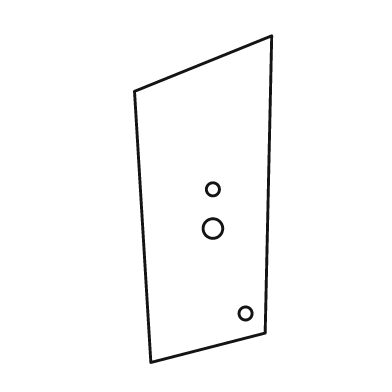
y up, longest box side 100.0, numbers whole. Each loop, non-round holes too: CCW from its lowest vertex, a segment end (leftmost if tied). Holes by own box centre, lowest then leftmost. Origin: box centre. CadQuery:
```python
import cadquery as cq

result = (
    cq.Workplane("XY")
    .moveTo(-16.0, -50.0)
    .lineTo(19.0, -41.0)
    .lineTo(21.0, 50.0)
    .lineTo(-21.0, 33.0)
    .close()
    .moveTo(13.0, -35.0)
    .circle(2.0)
    .moveTo(3.0, -9.0)
    .circle(3.0)
    .moveTo(3.0, 3.0)
    .circle(2.0)
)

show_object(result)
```